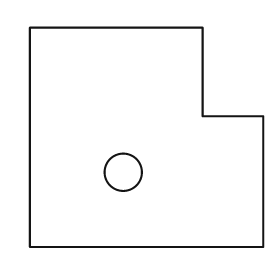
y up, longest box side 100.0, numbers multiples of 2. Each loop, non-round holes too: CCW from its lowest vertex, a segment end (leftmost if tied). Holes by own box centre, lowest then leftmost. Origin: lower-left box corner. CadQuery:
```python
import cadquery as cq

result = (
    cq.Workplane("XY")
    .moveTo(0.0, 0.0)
    .lineTo(100.0, 0.0)
    .lineTo(100.0, 56.0)
    .lineTo(74.0, 56.0)
    .lineTo(74.0, 94.0)
    .lineTo(0.0, 94.0)
    .close()
    .moveTo(40.0, 32.0)
    .circle(8.0)
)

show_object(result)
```